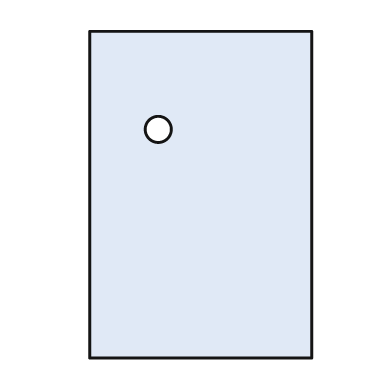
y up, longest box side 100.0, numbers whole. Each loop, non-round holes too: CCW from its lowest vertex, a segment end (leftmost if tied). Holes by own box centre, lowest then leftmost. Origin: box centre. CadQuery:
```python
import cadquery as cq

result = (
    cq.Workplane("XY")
    .moveTo(-34.0, -50.0)
    .lineTo(34.0, -50.0)
    .lineTo(34.0, 50.0)
    .lineTo(-34.0, 50.0)
    .close()
    .moveTo(-13.0, 20.0)
    .circle(4.0)
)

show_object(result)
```